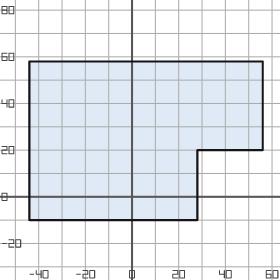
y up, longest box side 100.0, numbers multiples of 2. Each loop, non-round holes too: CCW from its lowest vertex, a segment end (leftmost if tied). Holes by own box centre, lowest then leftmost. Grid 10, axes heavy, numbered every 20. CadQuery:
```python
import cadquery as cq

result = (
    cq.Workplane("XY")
    .moveTo(-44.0, -10.0)
    .lineTo(28.0, -10.0)
    .lineTo(28.0, 20.0)
    .lineTo(56.0, 20.0)
    .lineTo(56.0, 58.0)
    .lineTo(-44.0, 58.0)
    .close()
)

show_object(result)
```